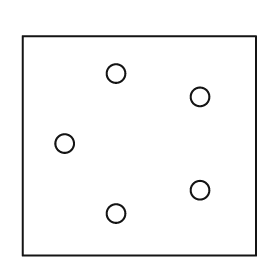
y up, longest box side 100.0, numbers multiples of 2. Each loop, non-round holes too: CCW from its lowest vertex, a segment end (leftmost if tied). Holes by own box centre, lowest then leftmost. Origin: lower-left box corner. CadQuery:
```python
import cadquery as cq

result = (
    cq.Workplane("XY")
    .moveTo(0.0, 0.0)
    .lineTo(100.0, 0.0)
    .lineTo(100.0, 94.0)
    .lineTo(0.0, 94.0)
    .close()
    .moveTo(40.0, 18.0)
    .circle(4.0)
    .moveTo(76.0, 28.0)
    .circle(4.0)
    .moveTo(18.0, 48.0)
    .circle(4.0)
    .moveTo(76.0, 68.0)
    .circle(4.0)
    .moveTo(40.0, 78.0)
    .circle(4.0)
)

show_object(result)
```